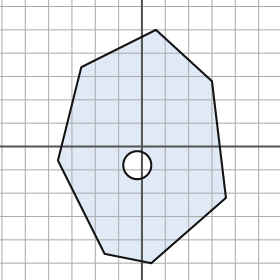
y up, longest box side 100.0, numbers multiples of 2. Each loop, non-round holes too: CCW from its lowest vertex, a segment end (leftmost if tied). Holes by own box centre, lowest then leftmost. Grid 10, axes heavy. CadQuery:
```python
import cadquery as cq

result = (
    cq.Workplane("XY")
    .moveTo(4.0, -50.0)
    .lineTo(36.0, -22.0)
    .lineTo(30.0, 28.0)
    .lineTo(6.0, 50.0)
    .lineTo(-26.0, 34.0)
    .lineTo(-36.0, -6.0)
    .lineTo(-16.0, -46.0)
    .close()
    .moveTo(-2.0, -8.0)
    .circle(6.0)
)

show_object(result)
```